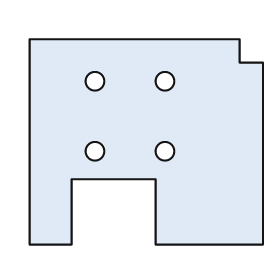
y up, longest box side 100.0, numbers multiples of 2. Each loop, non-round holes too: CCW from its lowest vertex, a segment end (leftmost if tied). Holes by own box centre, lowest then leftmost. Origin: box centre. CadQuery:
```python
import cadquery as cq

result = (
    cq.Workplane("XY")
    .moveTo(-50.0, -44.0)
    .lineTo(-32.0, -44.0)
    .lineTo(-32.0, -16.0)
    .lineTo(4.0, -16.0)
    .lineTo(4.0, -44.0)
    .lineTo(50.0, -44.0)
    .lineTo(50.0, 34.0)
    .lineTo(40.0, 34.0)
    .lineTo(40.0, 44.0)
    .lineTo(-50.0, 44.0)
    .close()
    .moveTo(-22.0, -4.0)
    .circle(4.0)
    .moveTo(8.0, -4.0)
    .circle(4.0)
    .moveTo(-22.0, 26.0)
    .circle(4.0)
    .moveTo(8.0, 26.0)
    .circle(4.0)
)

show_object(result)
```